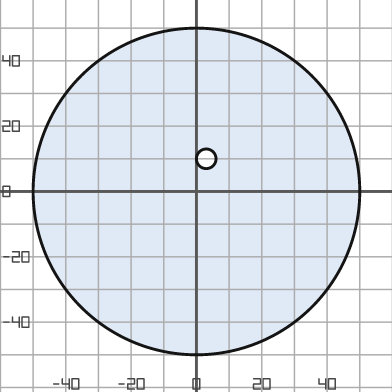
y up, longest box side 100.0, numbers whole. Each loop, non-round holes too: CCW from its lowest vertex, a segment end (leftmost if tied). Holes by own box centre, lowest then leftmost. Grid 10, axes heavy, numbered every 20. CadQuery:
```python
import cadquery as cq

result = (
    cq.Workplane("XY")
    .moveTo(0.0, 0.0)
    .circle(50.0)
    .moveTo(3.0, 10.0)
    .circle(3.0)
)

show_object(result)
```